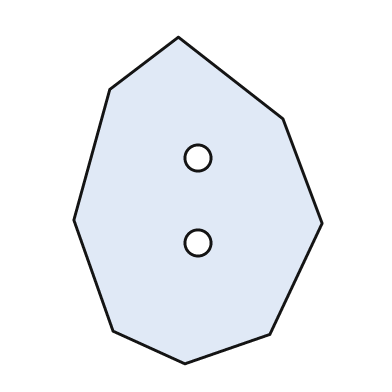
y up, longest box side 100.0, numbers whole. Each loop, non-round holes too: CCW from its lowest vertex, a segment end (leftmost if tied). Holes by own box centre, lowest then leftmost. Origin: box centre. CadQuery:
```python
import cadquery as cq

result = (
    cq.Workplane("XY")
    .moveTo(-4.0, -50.0)
    .lineTo(22.0, -41.0)
    .lineTo(38.0, -7.0)
    .lineTo(26.0, 25.0)
    .lineTo(-6.0, 50.0)
    .lineTo(-27.0, 34.0)
    .lineTo(-38.0, -6.0)
    .lineTo(-26.0, -40.0)
    .close()
    .moveTo(0.0, -13.0)
    .circle(4.0)
    .moveTo(0.0, 13.0)
    .circle(4.0)
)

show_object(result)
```